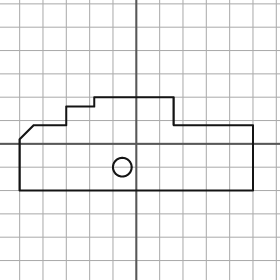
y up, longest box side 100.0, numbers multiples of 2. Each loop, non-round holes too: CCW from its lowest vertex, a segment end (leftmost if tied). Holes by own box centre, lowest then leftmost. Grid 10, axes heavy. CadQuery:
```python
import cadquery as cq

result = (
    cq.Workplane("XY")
    .moveTo(-50.0, -20.0)
    .lineTo(50.0, -20.0)
    .lineTo(50.0, 8.0)
    .lineTo(16.0, 8.0)
    .lineTo(16.0, 20.0)
    .lineTo(-18.0, 20.0)
    .lineTo(-18.0, 16.0)
    .lineTo(-30.0, 16.0)
    .lineTo(-30.0, 8.0)
    .lineTo(-44.0, 8.0)
    .lineTo(-50.0, 2.0)
    .close()
    .moveTo(-6.0, -10.0)
    .circle(4.0)
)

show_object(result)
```